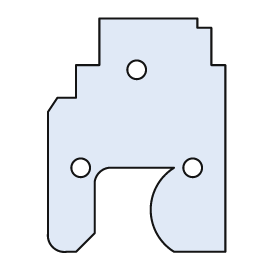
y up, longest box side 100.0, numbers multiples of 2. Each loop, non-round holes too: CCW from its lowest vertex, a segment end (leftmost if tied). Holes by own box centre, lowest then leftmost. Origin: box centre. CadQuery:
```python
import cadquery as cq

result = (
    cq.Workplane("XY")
    .moveTo(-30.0, -50.0)
    .lineTo(-26.0, -50.0)
    .lineTo(-18.0, -42.0)
    .lineTo(-18.0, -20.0)
    .threePointArc((-16.0, -16.0), (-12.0, -14.0))
    .lineTo(16.0, -14.0)
    .threePointArc((6.0, -32.0), (16.0, -50.0))
    .lineTo(38.0, -50.0)
    .lineTo(38.0, 30.0)
    .lineTo(32.0, 30.0)
    .lineTo(32.0, 46.0)
    .lineTo(26.0, 46.0)
    .lineTo(26.0, 50.0)
    .lineTo(-16.0, 50.0)
    .lineTo(-16.0, 30.0)
    .lineTo(-26.0, 30.0)
    .lineTo(-26.0, 16.0)
    .lineTo(-34.0, 16.0)
    .lineTo(-38.0, 10.0)
    .lineTo(-38.0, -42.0)
    .threePointArc((-36.0, -48.0), (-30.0, -50.0))
    .close()
    .moveTo(-24.0, -14.0)
    .circle(4.0)
    .moveTo(24.0, -14.0)
    .circle(4.0)
    .moveTo(0.0, 28.0)
    .circle(4.0)
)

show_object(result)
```